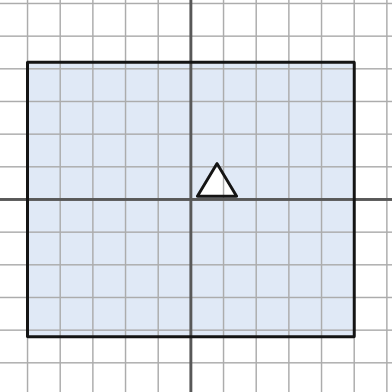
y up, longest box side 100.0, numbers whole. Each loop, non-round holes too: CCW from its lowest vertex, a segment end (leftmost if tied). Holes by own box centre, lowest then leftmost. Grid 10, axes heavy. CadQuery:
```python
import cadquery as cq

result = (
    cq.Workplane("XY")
    .moveTo(-50.0, -42.0)
    .lineTo(50.0, -42.0)
    .lineTo(50.0, 42.0)
    .lineTo(-50.0, 42.0)
    .close()
    .moveTo(2.0, 1.0)
    .lineTo(14.0, 1.0)
    .lineTo(8.0, 11.0)
    .close()
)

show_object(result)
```